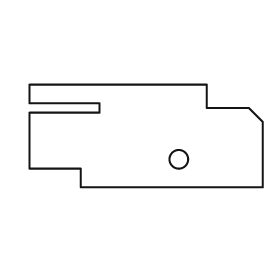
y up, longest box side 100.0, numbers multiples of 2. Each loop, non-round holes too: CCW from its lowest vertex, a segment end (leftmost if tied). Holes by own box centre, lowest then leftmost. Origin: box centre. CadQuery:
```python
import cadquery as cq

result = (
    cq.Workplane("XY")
    .moveTo(-28.0, -22.0)
    .lineTo(50.0, -22.0)
    .lineTo(50.0, 6.0)
    .lineTo(44.0, 12.0)
    .lineTo(26.0, 12.0)
    .lineTo(26.0, 22.0)
    .lineTo(-50.0, 22.0)
    .lineTo(-50.0, 14.0)
    .lineTo(-20.0, 14.0)
    .lineTo(-20.0, 10.0)
    .lineTo(-50.0, 10.0)
    .lineTo(-50.0, -14.0)
    .lineTo(-28.0, -14.0)
    .close()
    .moveTo(14.0, -10.0)
    .circle(4.0)
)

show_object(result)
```